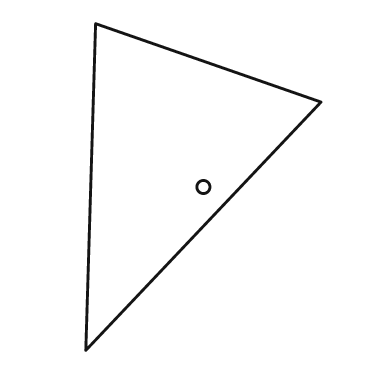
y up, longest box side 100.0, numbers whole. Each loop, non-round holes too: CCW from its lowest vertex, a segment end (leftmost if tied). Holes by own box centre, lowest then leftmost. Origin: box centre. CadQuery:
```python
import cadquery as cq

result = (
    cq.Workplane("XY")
    .moveTo(-36.0, -50.0)
    .lineTo(36.0, 26.0)
    .lineTo(-33.0, 50.0)
    .close()
    .moveTo(0.0, 0.0)
    .circle(2.0)
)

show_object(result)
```